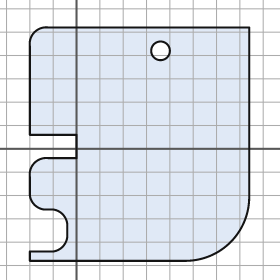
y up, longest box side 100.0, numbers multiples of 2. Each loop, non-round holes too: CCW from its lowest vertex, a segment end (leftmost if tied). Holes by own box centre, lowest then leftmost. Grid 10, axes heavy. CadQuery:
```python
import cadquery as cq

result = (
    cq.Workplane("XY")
    .moveTo(-20.0, -48.0)
    .lineTo(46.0, -48.0)
    .threePointArc((66.0, -40.0), (74.0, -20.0))
    .lineTo(74.0, 52.0)
    .lineTo(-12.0, 52.0)
    .threePointArc((-18.0, 50.0), (-20.0, 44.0))
    .lineTo(-20.0, 6.0)
    .lineTo(0.0, 6.0)
    .lineTo(0.0, -4.0)
    .lineTo(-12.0, -4.0)
    .threePointArc((-18.0, -6.0), (-20.0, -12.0))
    .lineTo(-20.0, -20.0)
    .threePointArc((-18.0, -24.0), (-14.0, -26.0))
    .lineTo(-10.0, -26.0)
    .threePointArc((-6.0, -28.0), (-4.0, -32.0))
    .lineTo(-4.0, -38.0)
    .threePointArc((-6.0, -42.0), (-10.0, -44.0))
    .lineTo(-20.0, -44.0)
    .close()
    .moveTo(36.0, 42.0)
    .circle(4.0)
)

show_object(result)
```